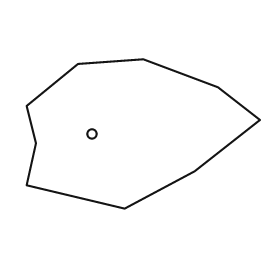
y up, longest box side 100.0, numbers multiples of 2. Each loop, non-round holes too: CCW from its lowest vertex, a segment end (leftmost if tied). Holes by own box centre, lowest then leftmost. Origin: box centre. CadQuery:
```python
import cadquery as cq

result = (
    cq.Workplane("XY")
    .moveTo(-8.0, -32.0)
    .lineTo(22.0, -16.0)
    .lineTo(50.0, 6.0)
    .lineTo(32.0, 20.0)
    .lineTo(0.0, 32.0)
    .lineTo(-28.0, 30.0)
    .lineTo(-50.0, 12.0)
    .lineTo(-46.0, -4.0)
    .lineTo(-50.0, -22.0)
    .close()
    .moveTo(-22.0, 0.0)
    .circle(2.0)
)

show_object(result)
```